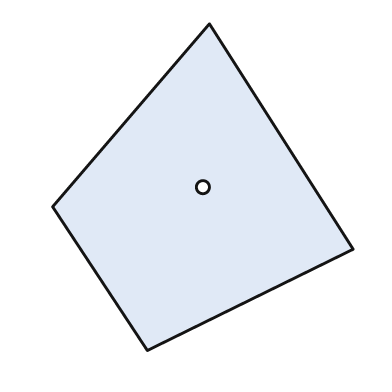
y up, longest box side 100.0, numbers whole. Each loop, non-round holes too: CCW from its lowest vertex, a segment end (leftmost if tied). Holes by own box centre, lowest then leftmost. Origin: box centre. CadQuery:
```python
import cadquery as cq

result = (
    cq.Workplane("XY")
    .moveTo(-17.0, -50.0)
    .lineTo(46.0, -19.0)
    .lineTo(2.0, 50.0)
    .lineTo(-46.0, -6.0)
    .close()
    .moveTo(0.0, 0.0)
    .circle(2.0)
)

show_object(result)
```